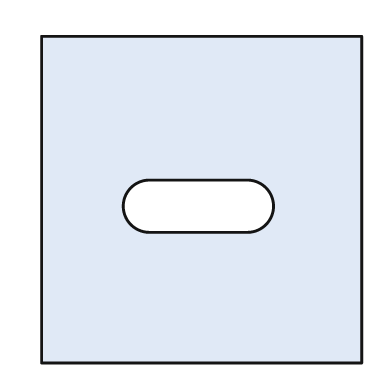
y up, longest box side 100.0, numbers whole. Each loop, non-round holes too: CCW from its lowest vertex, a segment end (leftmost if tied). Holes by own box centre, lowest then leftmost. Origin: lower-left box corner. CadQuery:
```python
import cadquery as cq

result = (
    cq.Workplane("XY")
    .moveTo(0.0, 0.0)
    .lineTo(98.0, 0.0)
    .lineTo(98.0, 100.0)
    .lineTo(0.0, 100.0)
    .close()
    .moveTo(33.0, 40.0)
    .lineTo(63.0, 40.0)
    .threePointArc((71.0, 48.0), (63.0, 56.0))
    .lineTo(33.0, 56.0)
    .threePointArc((25.0, 48.0), (33.0, 40.0))
    .close()
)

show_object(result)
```